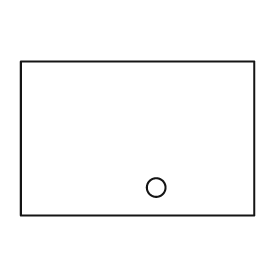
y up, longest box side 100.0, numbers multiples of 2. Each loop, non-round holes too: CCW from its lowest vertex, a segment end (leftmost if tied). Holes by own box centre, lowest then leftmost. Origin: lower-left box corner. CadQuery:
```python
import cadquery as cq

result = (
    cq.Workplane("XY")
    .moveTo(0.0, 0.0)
    .lineTo(100.0, 0.0)
    .lineTo(100.0, 66.0)
    .lineTo(0.0, 66.0)
    .close()
    .moveTo(58.0, 12.0)
    .circle(4.0)
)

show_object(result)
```